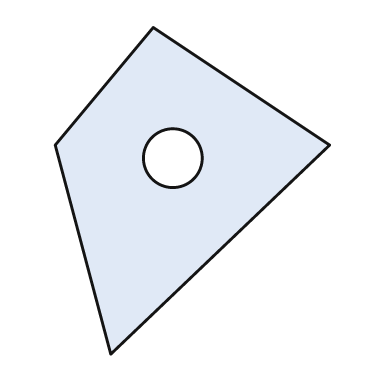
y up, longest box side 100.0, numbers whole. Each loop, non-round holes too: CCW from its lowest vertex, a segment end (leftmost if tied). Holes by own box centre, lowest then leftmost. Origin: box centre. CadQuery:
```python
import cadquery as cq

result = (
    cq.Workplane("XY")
    .moveTo(-25.0, -50.0)
    .lineTo(42.0, 14.0)
    .lineTo(-12.0, 50.0)
    .lineTo(-42.0, 14.0)
    .close()
    .moveTo(-6.0, 10.0)
    .circle(9.0)
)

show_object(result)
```